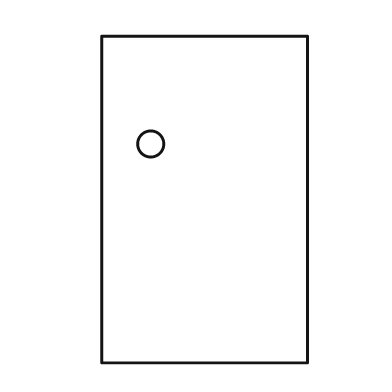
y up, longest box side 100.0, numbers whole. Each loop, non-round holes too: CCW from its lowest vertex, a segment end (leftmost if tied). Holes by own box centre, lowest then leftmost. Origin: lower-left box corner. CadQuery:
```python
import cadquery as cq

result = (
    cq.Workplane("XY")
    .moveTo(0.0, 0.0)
    .lineTo(63.0, 0.0)
    .lineTo(63.0, 100.0)
    .lineTo(0.0, 100.0)
    .close()
    .moveTo(15.0, 67.0)
    .circle(4.0)
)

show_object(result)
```